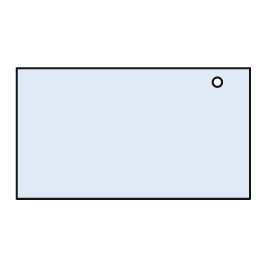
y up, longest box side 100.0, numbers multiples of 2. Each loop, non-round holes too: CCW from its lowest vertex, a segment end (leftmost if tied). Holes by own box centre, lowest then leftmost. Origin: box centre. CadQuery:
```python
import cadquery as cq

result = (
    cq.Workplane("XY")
    .moveTo(-50.0, -28.0)
    .lineTo(50.0, -28.0)
    .lineTo(50.0, 28.0)
    .lineTo(-50.0, 28.0)
    .close()
    .moveTo(36.0, 22.0)
    .circle(2.0)
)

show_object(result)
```